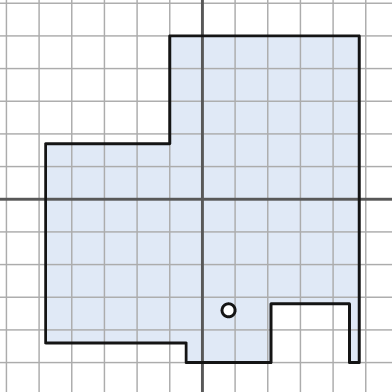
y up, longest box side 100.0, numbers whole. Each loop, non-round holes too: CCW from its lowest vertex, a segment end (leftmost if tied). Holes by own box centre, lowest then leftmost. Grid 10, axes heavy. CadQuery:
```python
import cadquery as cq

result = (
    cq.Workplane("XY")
    .moveTo(-5.0, -50.0)
    .lineTo(21.0, -50.0)
    .lineTo(21.0, -32.0)
    .lineTo(45.0, -32.0)
    .lineTo(45.0, -50.0)
    .lineTo(48.0, -50.0)
    .lineTo(48.0, 50.0)
    .lineTo(-10.0, 50.0)
    .lineTo(-10.0, 17.0)
    .lineTo(-48.0, 17.0)
    .lineTo(-48.0, -44.0)
    .lineTo(-5.0, -44.0)
    .close()
    .moveTo(8.0, -34.0)
    .circle(2.0)
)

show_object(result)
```